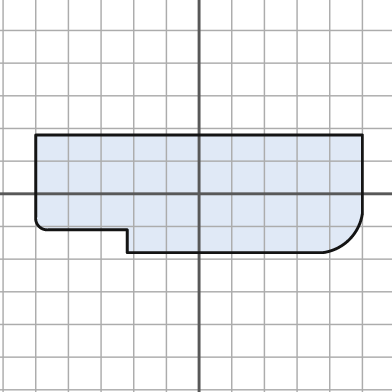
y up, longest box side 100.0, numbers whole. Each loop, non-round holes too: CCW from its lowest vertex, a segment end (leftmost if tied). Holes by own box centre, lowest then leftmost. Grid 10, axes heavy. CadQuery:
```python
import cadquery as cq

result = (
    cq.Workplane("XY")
    .moveTo(-22.0, -18.0)
    .lineTo(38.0, -18.0)
    .threePointArc((46.0, -14.0), (50.0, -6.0))
    .lineTo(50.0, 18.0)
    .lineTo(-50.0, 18.0)
    .lineTo(-50.0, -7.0)
    .threePointArc((-49.0, -10.0), (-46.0, -11.0))
    .lineTo(-22.0, -11.0)
    .close()
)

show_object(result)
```